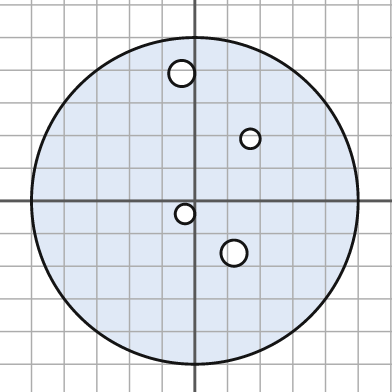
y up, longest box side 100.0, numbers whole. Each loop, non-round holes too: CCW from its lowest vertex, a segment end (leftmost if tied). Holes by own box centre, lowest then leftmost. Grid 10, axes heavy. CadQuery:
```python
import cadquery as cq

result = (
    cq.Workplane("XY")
    .moveTo(0.0, 0.0)
    .circle(50.0)
    .moveTo(12.0, -16.0)
    .circle(4.0)
    .moveTo(-3.0, -4.0)
    .circle(3.0)
    .moveTo(17.0, 19.0)
    .circle(3.0)
    .moveTo(-4.0, 39.0)
    .circle(4.0)
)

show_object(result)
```